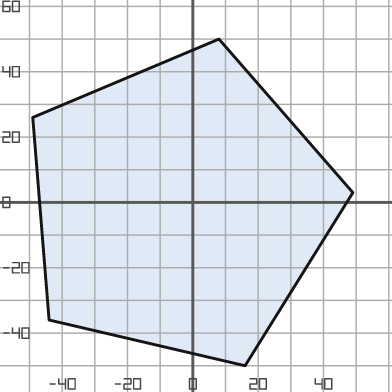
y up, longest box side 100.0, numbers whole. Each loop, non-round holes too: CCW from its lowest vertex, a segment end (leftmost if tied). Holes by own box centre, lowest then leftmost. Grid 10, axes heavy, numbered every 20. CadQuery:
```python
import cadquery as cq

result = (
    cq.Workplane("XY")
    .moveTo(16.0, -50.0)
    .lineTo(49.0, 3.0)
    .lineTo(8.0, 50.0)
    .lineTo(-49.0, 26.0)
    .lineTo(-44.0, -36.0)
    .close()
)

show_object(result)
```